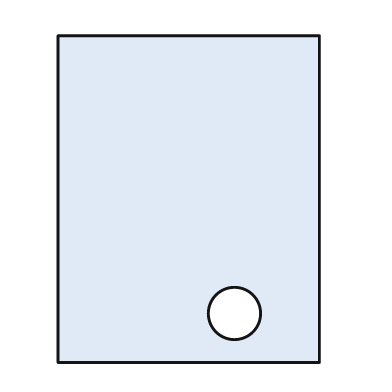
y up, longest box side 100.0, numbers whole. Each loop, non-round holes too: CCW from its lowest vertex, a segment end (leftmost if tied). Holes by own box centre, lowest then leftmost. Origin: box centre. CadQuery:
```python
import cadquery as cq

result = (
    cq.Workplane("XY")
    .moveTo(-40.0, -50.0)
    .lineTo(40.0, -50.0)
    .lineTo(40.0, 50.0)
    .lineTo(-40.0, 50.0)
    .close()
    .moveTo(14.0, -35.0)
    .circle(8.0)
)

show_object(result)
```